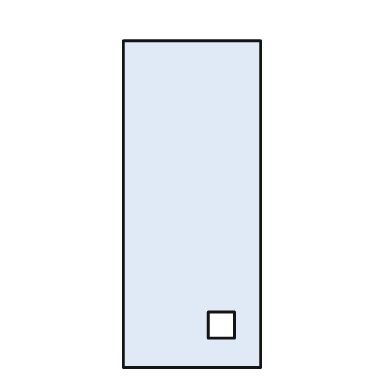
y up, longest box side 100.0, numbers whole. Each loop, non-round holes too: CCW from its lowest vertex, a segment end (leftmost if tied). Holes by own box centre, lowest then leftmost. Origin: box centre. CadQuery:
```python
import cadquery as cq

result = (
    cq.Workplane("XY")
    .moveTo(-21.0, -50.0)
    .lineTo(21.0, -50.0)
    .lineTo(21.0, 50.0)
    .lineTo(-21.0, 50.0)
    .close()
    .moveTo(5.0, -41.0)
    .lineTo(13.0, -41.0)
    .lineTo(13.0, -33.0)
    .lineTo(5.0, -33.0)
    .close()
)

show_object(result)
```